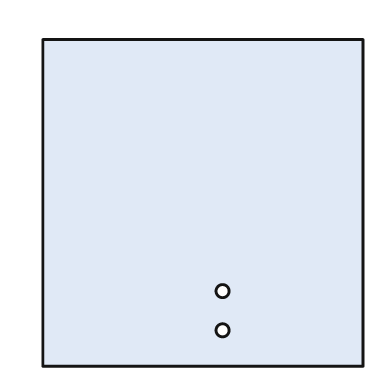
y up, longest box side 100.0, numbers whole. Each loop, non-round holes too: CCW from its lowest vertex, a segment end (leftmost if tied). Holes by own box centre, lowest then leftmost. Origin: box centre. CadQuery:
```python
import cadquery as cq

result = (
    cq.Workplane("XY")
    .moveTo(-49.0, -50.0)
    .lineTo(49.0, -50.0)
    .lineTo(49.0, 50.0)
    .lineTo(-49.0, 50.0)
    .close()
    .moveTo(6.0, -39.0)
    .circle(2.0)
    .moveTo(6.0, -27.0)
    .circle(2.0)
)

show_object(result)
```